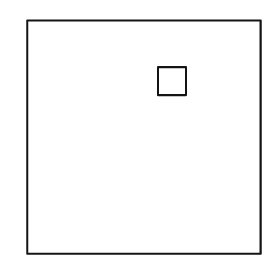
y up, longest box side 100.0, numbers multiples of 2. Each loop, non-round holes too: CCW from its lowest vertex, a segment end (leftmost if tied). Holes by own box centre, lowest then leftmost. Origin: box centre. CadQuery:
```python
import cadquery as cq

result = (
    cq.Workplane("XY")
    .moveTo(-50.0, -50.0)
    .lineTo(50.0, -50.0)
    .lineTo(50.0, 50.0)
    .lineTo(-50.0, 50.0)
    .close()
    .moveTo(6.0, 18.0)
    .lineTo(18.0, 18.0)
    .lineTo(18.0, 30.0)
    .lineTo(6.0, 30.0)
    .close()
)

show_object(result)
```